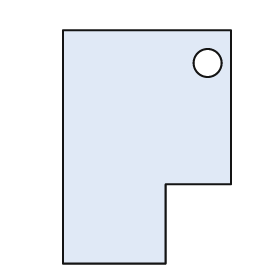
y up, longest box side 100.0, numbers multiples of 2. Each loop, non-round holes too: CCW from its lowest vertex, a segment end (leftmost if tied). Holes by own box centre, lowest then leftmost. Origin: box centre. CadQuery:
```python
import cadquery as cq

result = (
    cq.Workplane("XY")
    .moveTo(-36.0, -50.0)
    .lineTo(8.0, -50.0)
    .lineTo(8.0, -16.0)
    .lineTo(36.0, -16.0)
    .lineTo(36.0, 50.0)
    .lineTo(-36.0, 50.0)
    .close()
    .moveTo(26.0, 36.0)
    .circle(6.0)
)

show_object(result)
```